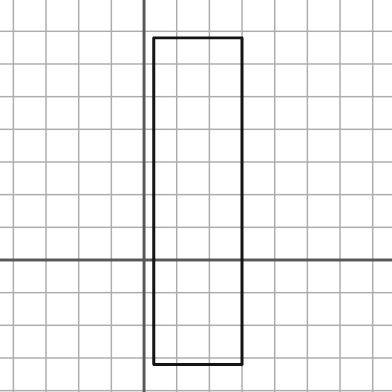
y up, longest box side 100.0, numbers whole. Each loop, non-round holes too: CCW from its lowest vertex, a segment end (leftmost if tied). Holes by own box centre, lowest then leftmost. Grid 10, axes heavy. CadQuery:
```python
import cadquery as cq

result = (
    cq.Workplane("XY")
    .moveTo(3.0, -32.0)
    .lineTo(30.0, -32.0)
    .lineTo(30.0, 68.0)
    .lineTo(3.0, 68.0)
    .close()
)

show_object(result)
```